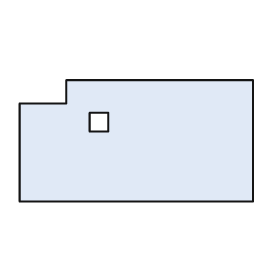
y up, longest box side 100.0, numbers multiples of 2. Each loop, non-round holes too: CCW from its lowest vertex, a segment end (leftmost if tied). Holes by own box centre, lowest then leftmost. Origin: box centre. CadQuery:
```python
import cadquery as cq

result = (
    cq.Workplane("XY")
    .moveTo(-50.0, -26.0)
    .lineTo(50.0, -26.0)
    .lineTo(50.0, 26.0)
    .lineTo(-30.0, 26.0)
    .lineTo(-30.0, 16.0)
    .lineTo(-50.0, 16.0)
    .close()
    .moveTo(-20.0, 4.0)
    .lineTo(-12.0, 4.0)
    .lineTo(-12.0, 12.0)
    .lineTo(-20.0, 12.0)
    .close()
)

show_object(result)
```